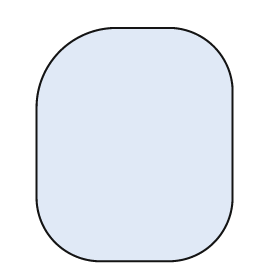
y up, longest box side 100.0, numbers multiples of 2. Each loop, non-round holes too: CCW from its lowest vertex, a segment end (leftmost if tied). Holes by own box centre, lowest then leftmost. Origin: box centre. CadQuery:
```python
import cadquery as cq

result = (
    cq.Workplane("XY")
    .moveTo(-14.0, -50.0)
    .lineTo(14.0, -50.0)
    .threePointArc((34.0, -42.0), (42.0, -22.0))
    .lineTo(42.0, 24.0)
    .threePointArc((34.0, 42.0), (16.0, 50.0))
    .lineTo(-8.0, 50.0)
    .threePointArc((-32.0, 40.0), (-42.0, 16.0))
    .lineTo(-42.0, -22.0)
    .threePointArc((-34.0, -42.0), (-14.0, -50.0))
    .close()
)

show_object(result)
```